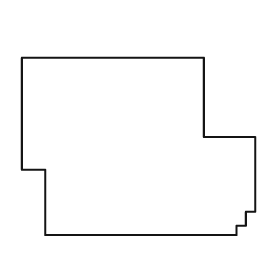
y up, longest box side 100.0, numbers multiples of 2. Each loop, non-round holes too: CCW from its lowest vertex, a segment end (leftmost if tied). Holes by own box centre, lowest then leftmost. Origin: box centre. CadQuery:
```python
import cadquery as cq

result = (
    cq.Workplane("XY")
    .moveTo(-40.0, -38.0)
    .lineTo(42.0, -38.0)
    .lineTo(42.0, -34.0)
    .lineTo(46.0, -34.0)
    .lineTo(46.0, -28.0)
    .lineTo(50.0, -28.0)
    .lineTo(50.0, 4.0)
    .lineTo(28.0, 4.0)
    .lineTo(28.0, 38.0)
    .lineTo(-50.0, 38.0)
    .lineTo(-50.0, -10.0)
    .lineTo(-40.0, -10.0)
    .close()
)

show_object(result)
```